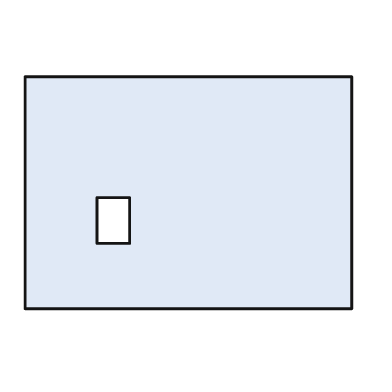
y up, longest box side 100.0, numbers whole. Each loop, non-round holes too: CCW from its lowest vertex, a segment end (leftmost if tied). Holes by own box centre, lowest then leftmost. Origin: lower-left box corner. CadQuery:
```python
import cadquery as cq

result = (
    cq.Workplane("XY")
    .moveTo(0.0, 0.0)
    .lineTo(100.0, 0.0)
    .lineTo(100.0, 71.0)
    .lineTo(0.0, 71.0)
    .close()
    .moveTo(22.0, 20.0)
    .lineTo(32.0, 20.0)
    .lineTo(32.0, 34.0)
    .lineTo(22.0, 34.0)
    .close()
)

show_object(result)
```